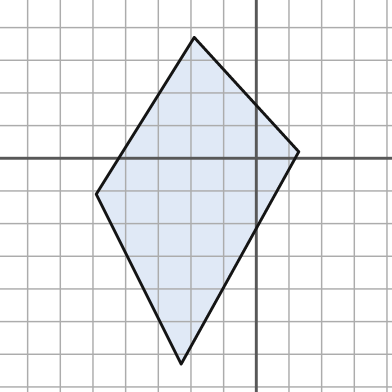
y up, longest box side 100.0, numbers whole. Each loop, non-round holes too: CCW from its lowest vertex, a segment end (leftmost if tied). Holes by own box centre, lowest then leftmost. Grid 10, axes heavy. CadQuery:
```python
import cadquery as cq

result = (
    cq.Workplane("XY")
    .moveTo(-23.0, -63.0)
    .lineTo(13.0, 2.0)
    .lineTo(-19.0, 37.0)
    .lineTo(-49.0, -11.0)
    .close()
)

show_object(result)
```